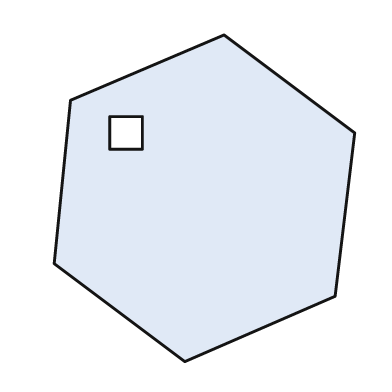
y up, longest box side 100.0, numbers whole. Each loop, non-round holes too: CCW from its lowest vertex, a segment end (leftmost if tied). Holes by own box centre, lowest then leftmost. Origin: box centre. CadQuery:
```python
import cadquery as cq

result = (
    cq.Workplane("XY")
    .moveTo(-6.0, -50.0)
    .lineTo(40.0, -30.0)
    .lineTo(46.0, 20.0)
    .lineTo(6.0, 50.0)
    .lineTo(-41.0, 30.0)
    .lineTo(-46.0, -20.0)
    .close()
    .moveTo(-29.0, 15.0)
    .lineTo(-19.0, 15.0)
    .lineTo(-19.0, 25.0)
    .lineTo(-29.0, 25.0)
    .close()
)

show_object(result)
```